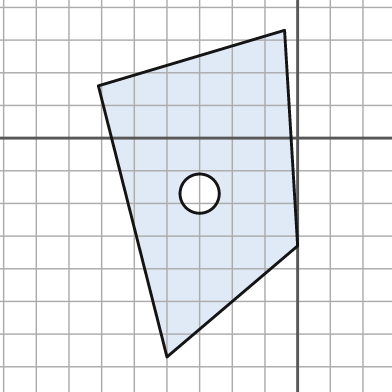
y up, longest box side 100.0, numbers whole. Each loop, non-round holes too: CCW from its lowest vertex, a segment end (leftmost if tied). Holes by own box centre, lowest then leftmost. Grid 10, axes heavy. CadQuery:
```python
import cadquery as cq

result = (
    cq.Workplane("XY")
    .moveTo(-40.0, -67.0)
    .lineTo(0.0, -33.0)
    .lineTo(-4.0, 33.0)
    .lineTo(-61.0, 16.0)
    .close()
    .moveTo(-30.0, -17.0)
    .circle(6.0)
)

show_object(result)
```